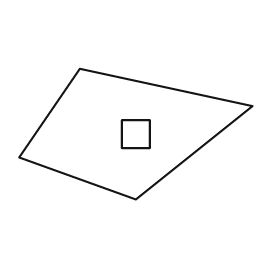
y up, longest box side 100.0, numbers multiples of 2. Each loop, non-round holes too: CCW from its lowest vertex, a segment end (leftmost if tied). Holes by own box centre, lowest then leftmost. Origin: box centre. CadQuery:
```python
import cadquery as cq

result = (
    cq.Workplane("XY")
    .moveTo(0.0, -28.0)
    .lineTo(50.0, 12.0)
    .lineTo(-24.0, 28.0)
    .lineTo(-50.0, -10.0)
    .close()
    .moveTo(-6.0, -6.0)
    .lineTo(6.0, -6.0)
    .lineTo(6.0, 6.0)
    .lineTo(-6.0, 6.0)
    .close()
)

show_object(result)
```